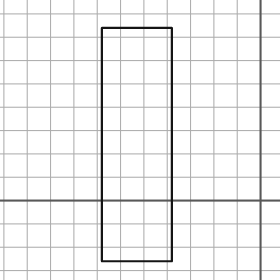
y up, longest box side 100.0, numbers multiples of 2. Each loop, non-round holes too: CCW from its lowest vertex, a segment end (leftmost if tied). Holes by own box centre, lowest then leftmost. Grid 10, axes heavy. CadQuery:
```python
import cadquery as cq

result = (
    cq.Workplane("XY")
    .moveTo(-68.0, -26.0)
    .lineTo(-38.0, -26.0)
    .lineTo(-38.0, 74.0)
    .lineTo(-68.0, 74.0)
    .close()
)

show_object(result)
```